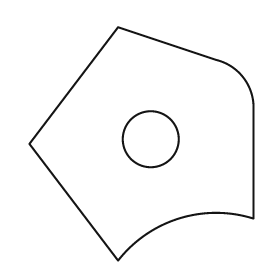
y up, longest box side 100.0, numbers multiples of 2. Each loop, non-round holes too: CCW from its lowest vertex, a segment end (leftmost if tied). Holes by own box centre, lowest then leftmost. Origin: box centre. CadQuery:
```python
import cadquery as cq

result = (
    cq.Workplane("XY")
    .moveTo(-10.0, -50.0)
    .threePointArc((16.0, -32.0), (48.0, -32.0))
    .lineTo(48.0, 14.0)
    .threePointArc((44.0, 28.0), (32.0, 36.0))
    .lineTo(-10.0, 50.0)
    .lineTo(-48.0, 0.0)
    .close()
    .moveTo(4.0, 2.0)
    .circle(12.0)
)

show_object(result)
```